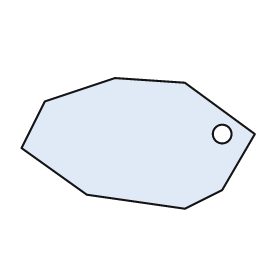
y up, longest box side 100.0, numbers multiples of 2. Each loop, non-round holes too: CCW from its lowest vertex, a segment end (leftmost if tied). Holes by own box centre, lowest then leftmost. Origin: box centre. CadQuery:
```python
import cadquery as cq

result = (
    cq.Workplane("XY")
    .moveTo(20.0, -28.0)
    .lineTo(36.0, -20.0)
    .lineTo(50.0, 4.0)
    .lineTo(20.0, 26.0)
    .lineTo(-10.0, 28.0)
    .lineTo(-40.0, 18.0)
    .lineTo(-50.0, -2.0)
    .lineTo(-22.0, -22.0)
    .close()
    .moveTo(36.0, 4.0)
    .circle(4.0)
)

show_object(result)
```